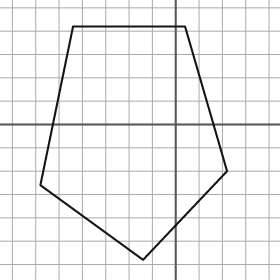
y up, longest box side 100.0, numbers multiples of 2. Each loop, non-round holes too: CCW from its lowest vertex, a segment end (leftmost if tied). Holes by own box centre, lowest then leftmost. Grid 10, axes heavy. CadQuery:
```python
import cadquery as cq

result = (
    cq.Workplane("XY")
    .moveTo(-14.0, -58.0)
    .lineTo(22.0, -20.0)
    .lineTo(4.0, 42.0)
    .lineTo(-44.0, 42.0)
    .lineTo(-58.0, -26.0)
    .close()
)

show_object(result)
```